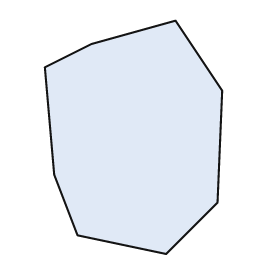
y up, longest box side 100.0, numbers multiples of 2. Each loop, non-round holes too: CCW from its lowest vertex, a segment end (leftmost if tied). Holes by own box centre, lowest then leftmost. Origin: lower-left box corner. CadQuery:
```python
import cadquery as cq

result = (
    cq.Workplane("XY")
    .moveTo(52.0, 0.0)
    .lineTo(74.0, 22.0)
    .lineTo(76.0, 70.0)
    .lineTo(56.0, 100.0)
    .lineTo(20.0, 90.0)
    .lineTo(0.0, 80.0)
    .lineTo(4.0, 34.0)
    .lineTo(14.0, 8.0)
    .close()
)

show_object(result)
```